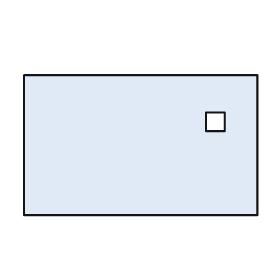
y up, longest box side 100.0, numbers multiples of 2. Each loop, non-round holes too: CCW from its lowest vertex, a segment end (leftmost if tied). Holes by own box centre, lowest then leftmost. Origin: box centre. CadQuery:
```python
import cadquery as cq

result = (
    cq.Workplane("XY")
    .moveTo(-50.0, -30.0)
    .lineTo(50.0, -30.0)
    .lineTo(50.0, 30.0)
    .lineTo(-50.0, 30.0)
    .close()
    .moveTo(28.0, 6.0)
    .lineTo(36.0, 6.0)
    .lineTo(36.0, 14.0)
    .lineTo(28.0, 14.0)
    .close()
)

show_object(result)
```